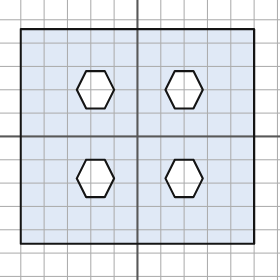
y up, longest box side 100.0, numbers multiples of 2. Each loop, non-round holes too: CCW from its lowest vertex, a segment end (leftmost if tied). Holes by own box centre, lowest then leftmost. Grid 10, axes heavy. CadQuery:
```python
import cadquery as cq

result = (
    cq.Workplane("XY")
    .moveTo(-50.0, -46.0)
    .lineTo(50.0, -46.0)
    .lineTo(50.0, 46.0)
    .lineTo(-50.0, 46.0)
    .close()
    .moveTo(-22.0, -26.0)
    .lineTo(-14.0, -26.0)
    .lineTo(-10.0, -18.0)
    .lineTo(-14.0, -10.0)
    .lineTo(-22.0, -10.0)
    .lineTo(-26.0, -18.0)
    .close()
    .moveTo(16.0, -26.0)
    .lineTo(24.0, -26.0)
    .lineTo(28.0, -18.0)
    .lineTo(24.0, -10.0)
    .lineTo(16.0, -10.0)
    .lineTo(12.0, -18.0)
    .close()
    .moveTo(-22.0, 12.0)
    .lineTo(-14.0, 12.0)
    .lineTo(-10.0, 20.0)
    .lineTo(-14.0, 28.0)
    .lineTo(-22.0, 28.0)
    .lineTo(-26.0, 20.0)
    .close()
    .moveTo(16.0, 12.0)
    .lineTo(24.0, 12.0)
    .lineTo(28.0, 20.0)
    .lineTo(24.0, 28.0)
    .lineTo(16.0, 28.0)
    .lineTo(12.0, 20.0)
    .close()
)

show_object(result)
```